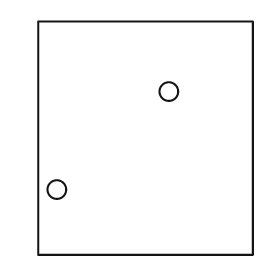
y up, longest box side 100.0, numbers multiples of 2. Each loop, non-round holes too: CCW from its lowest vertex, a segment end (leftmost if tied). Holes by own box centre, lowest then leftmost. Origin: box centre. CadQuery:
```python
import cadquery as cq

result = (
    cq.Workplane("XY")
    .moveTo(-46.0, -50.0)
    .lineTo(46.0, -50.0)
    .lineTo(46.0, 50.0)
    .lineTo(-46.0, 50.0)
    .close()
    .moveTo(-38.0, -22.0)
    .circle(4.0)
    .moveTo(10.0, 20.0)
    .circle(4.0)
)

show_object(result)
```